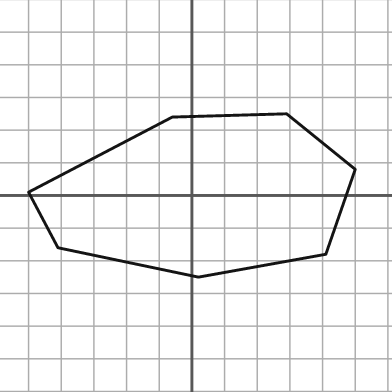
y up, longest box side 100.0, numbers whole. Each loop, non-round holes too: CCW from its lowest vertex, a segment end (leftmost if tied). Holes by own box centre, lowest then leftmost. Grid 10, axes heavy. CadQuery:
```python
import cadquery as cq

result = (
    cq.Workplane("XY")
    .moveTo(2.0, -25.0)
    .lineTo(41.0, -18.0)
    .lineTo(50.0, 8.0)
    .lineTo(29.0, 25.0)
    .lineTo(-6.0, 24.0)
    .lineTo(-50.0, 1.0)
    .lineTo(-41.0, -16.0)
    .close()
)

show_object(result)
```